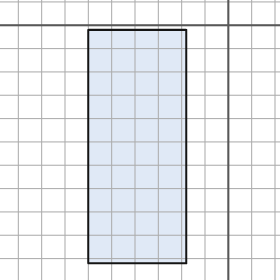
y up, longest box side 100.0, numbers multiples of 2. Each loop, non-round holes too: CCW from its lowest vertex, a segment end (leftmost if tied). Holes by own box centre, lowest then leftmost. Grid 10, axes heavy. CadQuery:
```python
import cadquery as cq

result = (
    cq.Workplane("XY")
    .moveTo(-60.0, -102.0)
    .lineTo(-18.0, -102.0)
    .lineTo(-18.0, -2.0)
    .lineTo(-60.0, -2.0)
    .close()
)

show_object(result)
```